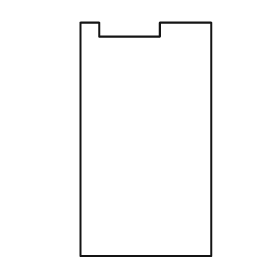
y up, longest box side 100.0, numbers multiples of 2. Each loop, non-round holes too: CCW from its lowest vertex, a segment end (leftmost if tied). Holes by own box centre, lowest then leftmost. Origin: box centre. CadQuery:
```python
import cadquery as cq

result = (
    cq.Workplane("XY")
    .moveTo(-28.0, -50.0)
    .lineTo(28.0, -50.0)
    .lineTo(28.0, 50.0)
    .lineTo(6.0, 50.0)
    .lineTo(6.0, 44.0)
    .lineTo(-20.0, 44.0)
    .lineTo(-20.0, 50.0)
    .lineTo(-28.0, 50.0)
    .close()
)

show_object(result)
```